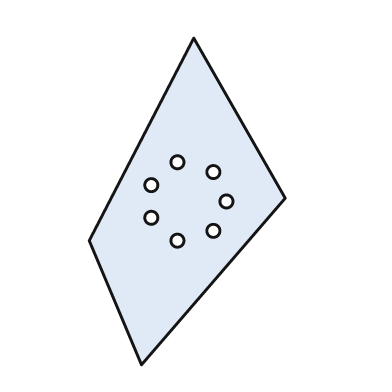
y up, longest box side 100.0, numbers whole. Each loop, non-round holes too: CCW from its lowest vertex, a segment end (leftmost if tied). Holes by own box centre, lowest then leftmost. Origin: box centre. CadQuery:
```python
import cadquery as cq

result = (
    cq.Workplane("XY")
    .moveTo(-14.0, -50.0)
    .lineTo(30.0, 1.0)
    .lineTo(2.0, 50.0)
    .lineTo(-30.0, -12.0)
    .close()
    .moveTo(-3.0, -12.0)
    .circle(2.0)
    .moveTo(8.0, -9.0)
    .circle(2.0)
    .moveTo(-11.0, -5.0)
    .circle(2.0)
    .moveTo(12.0, 0.0)
    .circle(2.0)
    .moveTo(-11.0, 5.0)
    .circle(2.0)
    .moveTo(8.0, 9.0)
    .circle(2.0)
    .moveTo(-3.0, 12.0)
    .circle(2.0)
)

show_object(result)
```